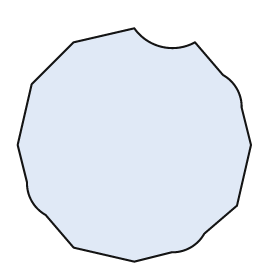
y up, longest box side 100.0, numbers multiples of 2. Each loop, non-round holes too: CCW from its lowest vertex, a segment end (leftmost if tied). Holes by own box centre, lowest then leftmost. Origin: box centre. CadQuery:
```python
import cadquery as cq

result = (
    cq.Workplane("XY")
    .moveTo(0.0, -50.0)
    .lineTo(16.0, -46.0)
    .threePointArc((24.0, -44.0), (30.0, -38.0))
    .lineTo(44.0, -26.0)
    .lineTo(50.0, 0.0)
    .lineTo(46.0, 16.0)
    .threePointArc((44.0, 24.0), (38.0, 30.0))
    .lineTo(26.0, 44.0)
    .threePointArc((12.0, 42.0), (0.0, 50.0))
    .lineTo(-26.0, 44.0)
    .lineTo(-44.0, 26.0)
    .lineTo(-50.0, 0.0)
    .lineTo(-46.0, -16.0)
    .threePointArc((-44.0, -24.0), (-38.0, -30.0))
    .lineTo(-26.0, -44.0)
    .close()
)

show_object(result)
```